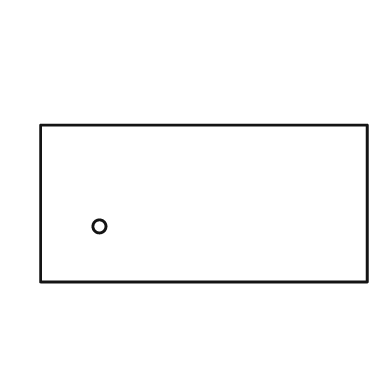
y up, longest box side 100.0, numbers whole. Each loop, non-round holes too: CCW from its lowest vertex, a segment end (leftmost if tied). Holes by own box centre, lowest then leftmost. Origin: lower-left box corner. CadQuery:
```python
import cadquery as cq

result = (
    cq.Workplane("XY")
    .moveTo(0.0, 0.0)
    .lineTo(100.0, 0.0)
    .lineTo(100.0, 48.0)
    .lineTo(0.0, 48.0)
    .close()
    .moveTo(18.0, 17.0)
    .circle(2.0)
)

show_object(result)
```